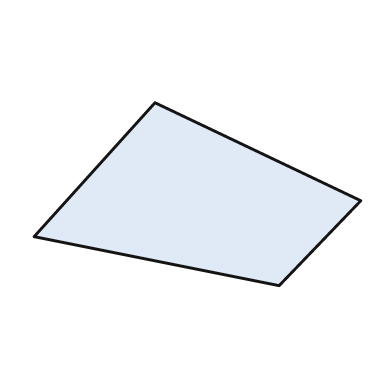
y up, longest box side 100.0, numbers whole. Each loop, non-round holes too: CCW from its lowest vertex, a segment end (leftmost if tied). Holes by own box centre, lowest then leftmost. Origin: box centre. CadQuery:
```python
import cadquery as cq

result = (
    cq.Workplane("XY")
    .moveTo(25.0, -28.0)
    .lineTo(50.0, -2.0)
    .lineTo(-13.0, 28.0)
    .lineTo(-50.0, -13.0)
    .close()
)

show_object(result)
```